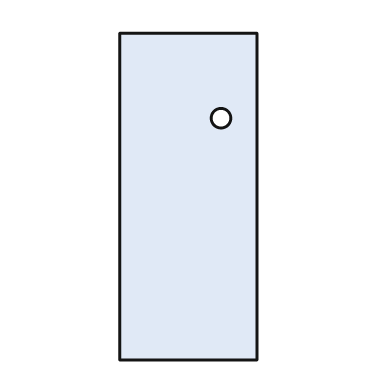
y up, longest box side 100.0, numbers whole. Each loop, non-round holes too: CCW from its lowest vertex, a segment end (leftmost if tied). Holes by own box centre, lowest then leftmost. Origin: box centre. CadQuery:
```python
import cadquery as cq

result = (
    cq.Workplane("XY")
    .moveTo(-21.0, -50.0)
    .lineTo(21.0, -50.0)
    .lineTo(21.0, 50.0)
    .lineTo(-21.0, 50.0)
    .close()
    .moveTo(10.0, 24.0)
    .circle(3.0)
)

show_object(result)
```